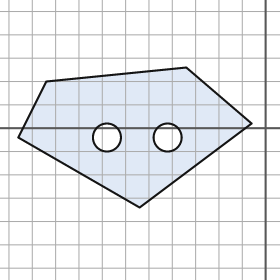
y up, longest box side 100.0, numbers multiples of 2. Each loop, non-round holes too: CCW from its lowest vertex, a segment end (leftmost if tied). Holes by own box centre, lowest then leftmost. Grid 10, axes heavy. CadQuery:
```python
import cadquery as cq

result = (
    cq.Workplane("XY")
    .moveTo(-54.0, -34.0)
    .lineTo(-6.0, 2.0)
    .lineTo(-34.0, 26.0)
    .lineTo(-94.0, 20.0)
    .lineTo(-106.0, -4.0)
    .close()
    .moveTo(-68.0, -4.0)
    .circle(6.0)
    .moveTo(-42.0, -4.0)
    .circle(6.0)
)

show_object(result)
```